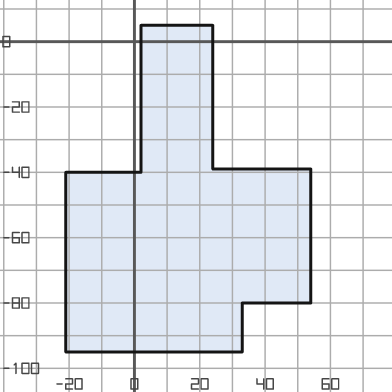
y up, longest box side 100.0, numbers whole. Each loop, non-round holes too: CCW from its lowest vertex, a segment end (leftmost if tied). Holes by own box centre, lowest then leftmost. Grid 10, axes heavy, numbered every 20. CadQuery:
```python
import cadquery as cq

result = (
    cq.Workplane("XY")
    .moveTo(-21.0, -95.0)
    .lineTo(33.0, -95.0)
    .lineTo(33.0, -80.0)
    .lineTo(54.0, -80.0)
    .lineTo(54.0, -39.0)
    .lineTo(24.0, -39.0)
    .lineTo(24.0, 5.0)
    .lineTo(2.0, 5.0)
    .lineTo(2.0, -40.0)
    .lineTo(-21.0, -40.0)
    .close()
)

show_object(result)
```